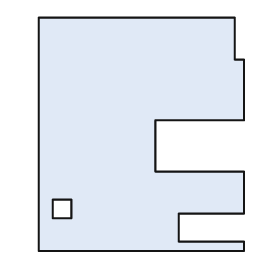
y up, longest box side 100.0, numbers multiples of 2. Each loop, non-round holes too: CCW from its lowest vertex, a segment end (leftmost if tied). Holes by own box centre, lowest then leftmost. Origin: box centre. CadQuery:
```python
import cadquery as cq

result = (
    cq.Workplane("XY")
    .moveTo(-44.0, -50.0)
    .lineTo(44.0, -50.0)
    .lineTo(44.0, -46.0)
    .lineTo(16.0, -46.0)
    .lineTo(16.0, -34.0)
    .lineTo(44.0, -34.0)
    .lineTo(44.0, -16.0)
    .lineTo(6.0, -16.0)
    .lineTo(6.0, 6.0)
    .lineTo(44.0, 6.0)
    .lineTo(44.0, 32.0)
    .lineTo(40.0, 32.0)
    .lineTo(40.0, 50.0)
    .lineTo(-44.0, 50.0)
    .close()
    .moveTo(-38.0, -36.0)
    .lineTo(-30.0, -36.0)
    .lineTo(-30.0, -28.0)
    .lineTo(-38.0, -28.0)
    .close()
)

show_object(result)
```